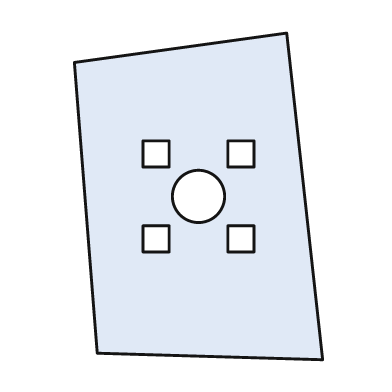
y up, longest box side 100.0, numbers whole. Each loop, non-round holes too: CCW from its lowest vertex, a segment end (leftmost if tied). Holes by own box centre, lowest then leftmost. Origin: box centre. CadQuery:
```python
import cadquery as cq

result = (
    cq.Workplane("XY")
    .moveTo(38.0, -50.0)
    .lineTo(27.0, 50.0)
    .lineTo(-38.0, 41.0)
    .lineTo(-31.0, -48.0)
    .close()
    .moveTo(-17.0, -17.0)
    .lineTo(-9.0, -17.0)
    .lineTo(-9.0, -9.0)
    .lineTo(-17.0, -9.0)
    .close()
    .moveTo(9.0, -17.0)
    .lineTo(17.0, -17.0)
    .lineTo(17.0, -9.0)
    .lineTo(9.0, -9.0)
    .close()
    .moveTo(0.0, 0.0)
    .circle(8.0)
    .moveTo(-17.0, 9.0)
    .lineTo(-9.0, 9.0)
    .lineTo(-9.0, 17.0)
    .lineTo(-17.0, 17.0)
    .close()
    .moveTo(9.0, 9.0)
    .lineTo(17.0, 9.0)
    .lineTo(17.0, 17.0)
    .lineTo(9.0, 17.0)
    .close()
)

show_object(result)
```